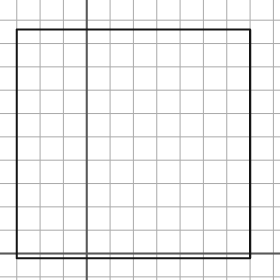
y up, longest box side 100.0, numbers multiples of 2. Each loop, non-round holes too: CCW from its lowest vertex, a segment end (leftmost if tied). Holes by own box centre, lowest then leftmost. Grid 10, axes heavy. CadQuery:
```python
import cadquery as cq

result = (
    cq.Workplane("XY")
    .moveTo(-30.0, -2.0)
    .lineTo(70.0, -2.0)
    .lineTo(70.0, 96.0)
    .lineTo(-30.0, 96.0)
    .close()
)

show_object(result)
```